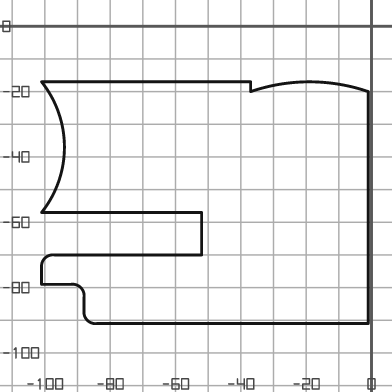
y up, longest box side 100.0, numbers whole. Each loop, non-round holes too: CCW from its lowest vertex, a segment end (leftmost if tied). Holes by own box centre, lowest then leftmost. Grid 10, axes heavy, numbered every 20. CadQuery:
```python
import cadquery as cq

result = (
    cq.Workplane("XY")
    .moveTo(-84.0, -91.0)
    .lineTo(-1.0, -91.0)
    .lineTo(-1.0, -20.0)
    .threePointArc((-19.0, -17.0), (-37.0, -20.0))
    .lineTo(-37.0, -17.0)
    .lineTo(-101.0, -17.0)
    .threePointArc((-94.0, -37.0), (-101.0, -57.0))
    .lineTo(-52.0, -57.0)
    .lineTo(-52.0, -70.0)
    .lineTo(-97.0, -70.0)
    .threePointArc((-100.0, -71.0), (-101.0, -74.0))
    .lineTo(-101.0, -79.0)
    .lineTo(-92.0, -79.0)
    .threePointArc((-89.0, -80.0), (-88.0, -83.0))
    .lineTo(-88.0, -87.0)
    .threePointArc((-87.0, -90.0), (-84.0, -91.0))
    .close()
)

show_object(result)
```